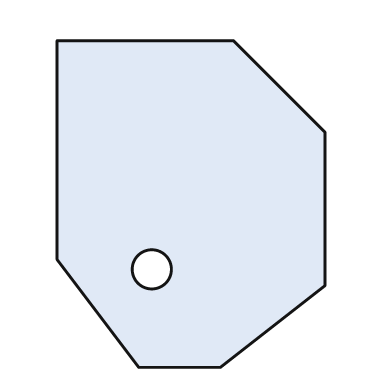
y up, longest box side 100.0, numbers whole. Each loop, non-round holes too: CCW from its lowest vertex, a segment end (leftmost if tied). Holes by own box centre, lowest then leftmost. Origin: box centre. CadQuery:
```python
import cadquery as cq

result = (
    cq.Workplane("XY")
    .moveTo(-16.0, -50.0)
    .lineTo(9.0, -50.0)
    .lineTo(41.0, -25.0)
    .lineTo(41.0, 22.0)
    .lineTo(13.0, 50.0)
    .lineTo(-41.0, 50.0)
    .lineTo(-41.0, -17.0)
    .close()
    .moveTo(-12.0, -20.0)
    .circle(6.0)
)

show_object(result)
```